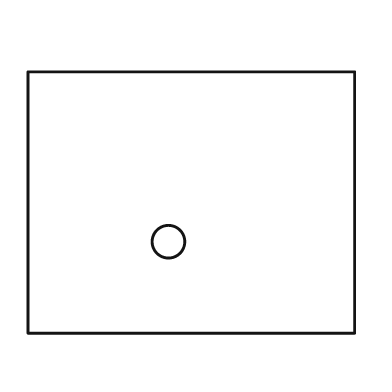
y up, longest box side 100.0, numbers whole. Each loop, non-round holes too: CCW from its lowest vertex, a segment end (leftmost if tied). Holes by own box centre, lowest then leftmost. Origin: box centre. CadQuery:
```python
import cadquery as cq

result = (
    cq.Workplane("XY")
    .moveTo(-50.0, -40.0)
    .lineTo(50.0, -40.0)
    .lineTo(50.0, 40.0)
    .lineTo(-50.0, 40.0)
    .close()
    .moveTo(-7.0, -12.0)
    .circle(5.0)
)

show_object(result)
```